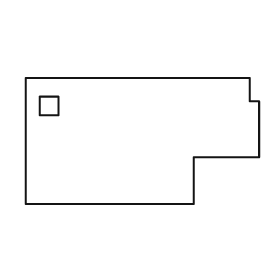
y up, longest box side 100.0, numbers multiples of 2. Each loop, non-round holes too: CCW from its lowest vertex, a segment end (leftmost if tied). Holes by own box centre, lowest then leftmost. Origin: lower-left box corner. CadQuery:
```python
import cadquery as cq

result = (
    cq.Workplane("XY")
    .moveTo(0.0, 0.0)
    .lineTo(72.0, 0.0)
    .lineTo(72.0, 20.0)
    .lineTo(100.0, 20.0)
    .lineTo(100.0, 44.0)
    .lineTo(96.0, 44.0)
    .lineTo(96.0, 54.0)
    .lineTo(0.0, 54.0)
    .close()
    .moveTo(6.0, 38.0)
    .lineTo(14.0, 38.0)
    .lineTo(14.0, 46.0)
    .lineTo(6.0, 46.0)
    .close()
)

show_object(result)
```